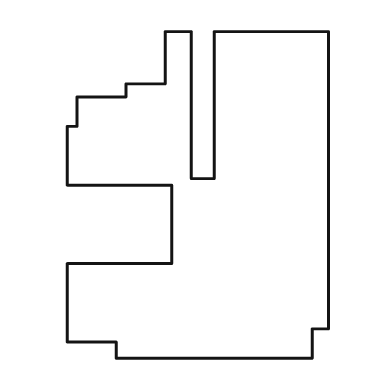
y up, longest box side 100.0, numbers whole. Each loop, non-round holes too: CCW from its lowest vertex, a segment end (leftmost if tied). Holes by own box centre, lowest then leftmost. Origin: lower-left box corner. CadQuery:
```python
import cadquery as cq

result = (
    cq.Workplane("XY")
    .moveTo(15.0, 0.0)
    .lineTo(75.0, 0.0)
    .lineTo(75.0, 9.0)
    .lineTo(80.0, 9.0)
    .lineTo(80.0, 100.0)
    .lineTo(45.0, 100.0)
    .lineTo(45.0, 55.0)
    .lineTo(38.0, 55.0)
    .lineTo(38.0, 100.0)
    .lineTo(30.0, 100.0)
    .lineTo(30.0, 84.0)
    .lineTo(18.0, 84.0)
    .lineTo(18.0, 80.0)
    .lineTo(3.0, 80.0)
    .lineTo(3.0, 71.0)
    .lineTo(0.0, 71.0)
    .lineTo(0.0, 53.0)
    .lineTo(32.0, 53.0)
    .lineTo(32.0, 29.0)
    .lineTo(0.0, 29.0)
    .lineTo(0.0, 5.0)
    .lineTo(15.0, 5.0)
    .close()
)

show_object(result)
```